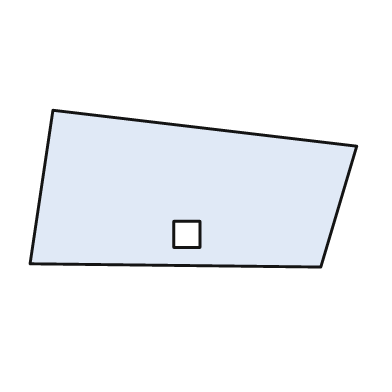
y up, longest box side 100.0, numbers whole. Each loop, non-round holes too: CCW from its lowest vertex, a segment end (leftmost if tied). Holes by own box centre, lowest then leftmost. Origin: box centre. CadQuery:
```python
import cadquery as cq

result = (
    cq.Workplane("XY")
    .moveTo(39.0, -24.0)
    .lineTo(50.0, 13.0)
    .lineTo(-43.0, 24.0)
    .lineTo(-50.0, -23.0)
    .close()
    .moveTo(-6.0, -18.0)
    .lineTo(2.0, -18.0)
    .lineTo(2.0, -10.0)
    .lineTo(-6.0, -10.0)
    .close()
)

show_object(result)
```